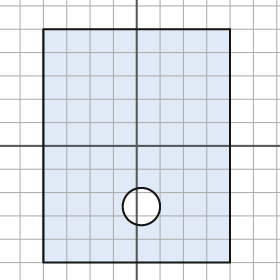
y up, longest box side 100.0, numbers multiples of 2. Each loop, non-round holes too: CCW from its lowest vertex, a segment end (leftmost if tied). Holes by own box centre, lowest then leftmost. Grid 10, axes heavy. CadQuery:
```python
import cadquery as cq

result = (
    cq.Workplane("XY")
    .moveTo(-40.0, -50.0)
    .lineTo(40.0, -50.0)
    .lineTo(40.0, 50.0)
    .lineTo(-40.0, 50.0)
    .close()
    .moveTo(2.0, -26.0)
    .circle(8.0)
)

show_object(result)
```